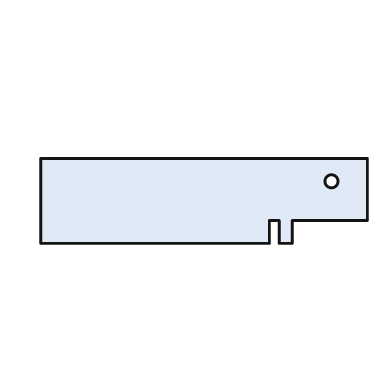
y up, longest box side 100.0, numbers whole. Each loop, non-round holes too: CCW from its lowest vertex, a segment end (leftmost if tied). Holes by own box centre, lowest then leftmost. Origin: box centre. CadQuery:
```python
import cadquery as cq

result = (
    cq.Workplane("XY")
    .moveTo(-50.0, -13.0)
    .lineTo(20.0, -13.0)
    .lineTo(20.0, -6.0)
    .lineTo(23.0, -6.0)
    .lineTo(23.0, -13.0)
    .lineTo(27.0, -13.0)
    .lineTo(27.0, -6.0)
    .lineTo(50.0, -6.0)
    .lineTo(50.0, 13.0)
    .lineTo(-50.0, 13.0)
    .close()
    .moveTo(39.0, 6.0)
    .circle(2.0)
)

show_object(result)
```